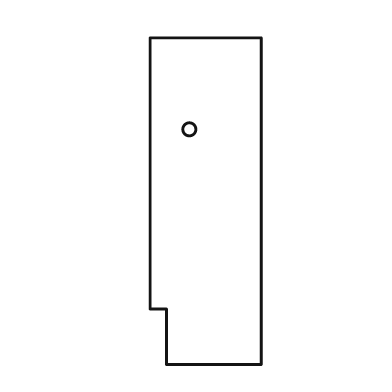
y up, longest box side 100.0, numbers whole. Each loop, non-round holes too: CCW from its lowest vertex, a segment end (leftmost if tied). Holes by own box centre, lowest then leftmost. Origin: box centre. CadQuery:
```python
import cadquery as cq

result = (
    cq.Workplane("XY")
    .moveTo(-12.0, -50.0)
    .lineTo(17.0, -50.0)
    .lineTo(17.0, 50.0)
    .lineTo(-17.0, 50.0)
    .lineTo(-17.0, -33.0)
    .lineTo(-12.0, -33.0)
    .close()
    .moveTo(-5.0, 22.0)
    .circle(2.0)
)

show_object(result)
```